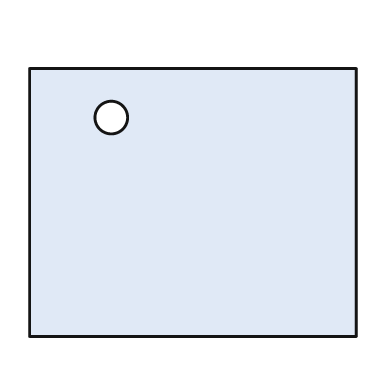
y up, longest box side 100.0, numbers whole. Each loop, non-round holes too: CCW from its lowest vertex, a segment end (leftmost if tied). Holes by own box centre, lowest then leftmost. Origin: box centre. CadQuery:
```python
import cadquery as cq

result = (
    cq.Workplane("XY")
    .moveTo(-50.0, -41.0)
    .lineTo(50.0, -41.0)
    .lineTo(50.0, 41.0)
    .lineTo(-50.0, 41.0)
    .close()
    .moveTo(-25.0, 26.0)
    .circle(5.0)
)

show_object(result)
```